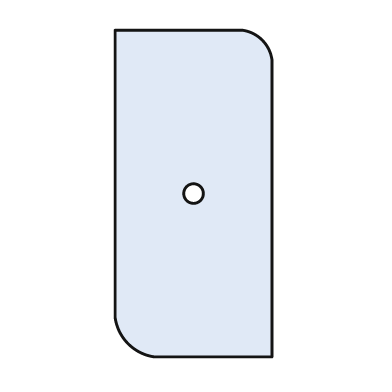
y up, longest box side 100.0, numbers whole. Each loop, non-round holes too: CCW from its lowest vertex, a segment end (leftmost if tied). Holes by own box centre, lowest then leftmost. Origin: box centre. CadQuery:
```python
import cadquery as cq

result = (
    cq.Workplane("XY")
    .moveTo(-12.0, -50.0)
    .lineTo(24.0, -50.0)
    .lineTo(24.0, 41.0)
    .threePointArc((21.0, 47.0), (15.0, 50.0))
    .lineTo(-24.0, 50.0)
    .lineTo(-24.0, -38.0)
    .threePointArc((-20.0, -46.0), (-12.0, -50.0))
    .close()
    .moveTo(0.0, 0.0)
    .circle(3.0)
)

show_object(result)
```